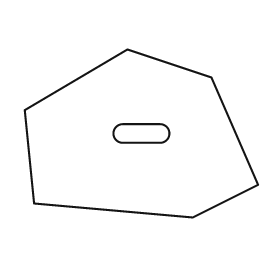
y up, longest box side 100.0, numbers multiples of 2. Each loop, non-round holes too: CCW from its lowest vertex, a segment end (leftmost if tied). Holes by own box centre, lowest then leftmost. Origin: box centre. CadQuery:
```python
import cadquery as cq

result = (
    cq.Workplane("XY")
    .moveTo(22.0, -36.0)
    .lineTo(50.0, -22.0)
    .lineTo(30.0, 24.0)
    .lineTo(-6.0, 36.0)
    .lineTo(-50.0, 10.0)
    .lineTo(-46.0, -30.0)
    .close()
    .moveTo(-8.0, -4.0)
    .lineTo(8.0, -4.0)
    .threePointArc((12.0, 0.0), (8.0, 4.0))
    .lineTo(-8.0, 4.0)
    .threePointArc((-12.0, 0.0), (-8.0, -4.0))
    .close()
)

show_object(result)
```